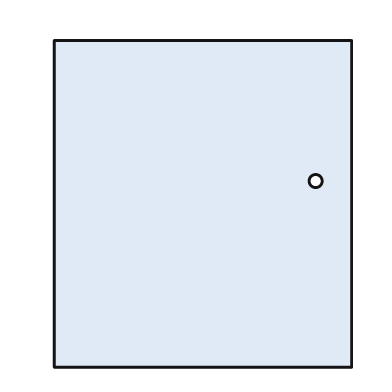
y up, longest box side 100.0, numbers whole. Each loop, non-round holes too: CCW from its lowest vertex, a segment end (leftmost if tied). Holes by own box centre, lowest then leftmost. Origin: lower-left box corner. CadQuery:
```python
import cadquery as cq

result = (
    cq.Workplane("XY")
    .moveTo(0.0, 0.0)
    .lineTo(91.0, 0.0)
    .lineTo(91.0, 100.0)
    .lineTo(0.0, 100.0)
    .close()
    .moveTo(80.0, 57.0)
    .circle(2.0)
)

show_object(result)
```